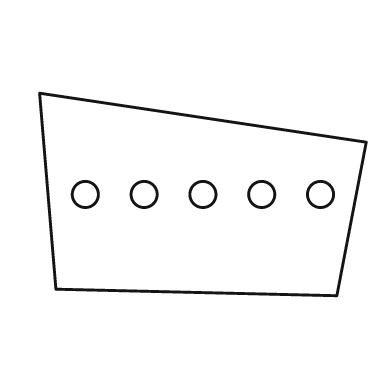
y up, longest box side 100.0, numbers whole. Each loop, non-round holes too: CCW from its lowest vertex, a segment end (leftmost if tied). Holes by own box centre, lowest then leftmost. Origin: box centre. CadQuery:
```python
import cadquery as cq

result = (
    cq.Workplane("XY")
    .moveTo(41.0, -31.0)
    .lineTo(50.0, 16.0)
    .lineTo(-50.0, 31.0)
    .lineTo(-45.0, -29.0)
    .close()
    .moveTo(-36.0, 0.0)
    .circle(4.0)
    .moveTo(-18.0, 0.0)
    .circle(4.0)
    .moveTo(0.0, 0.0)
    .circle(4.0)
    .moveTo(18.0, 0.0)
    .circle(4.0)
    .moveTo(36.0, 0.0)
    .circle(4.0)
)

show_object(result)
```